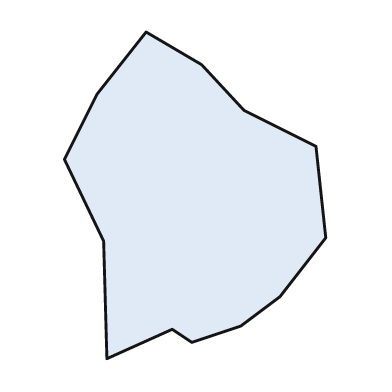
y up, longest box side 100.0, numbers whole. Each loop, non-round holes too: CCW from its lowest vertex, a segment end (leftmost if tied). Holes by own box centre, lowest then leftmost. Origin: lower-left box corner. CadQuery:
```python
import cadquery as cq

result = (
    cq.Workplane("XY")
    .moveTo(13.0, 0.0)
    .lineTo(33.0, 9.0)
    .lineTo(39.0, 5.0)
    .lineTo(54.0, 10.0)
    .lineTo(66.0, 19.0)
    .lineTo(80.0, 37.0)
    .lineTo(77.0, 65.0)
    .lineTo(55.0, 76.0)
    .lineTo(42.0, 90.0)
    .lineTo(25.0, 100.0)
    .lineTo(10.0, 81.0)
    .lineTo(0.0, 61.0)
    .lineTo(12.0, 36.0)
    .close()
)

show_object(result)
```